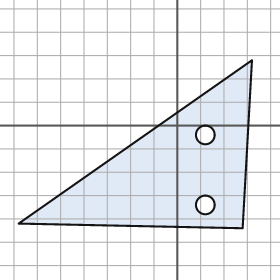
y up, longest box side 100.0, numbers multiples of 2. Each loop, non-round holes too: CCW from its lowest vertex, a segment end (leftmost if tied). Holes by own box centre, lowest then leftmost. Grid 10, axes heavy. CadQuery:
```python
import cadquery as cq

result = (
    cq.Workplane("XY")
    .moveTo(28.0, -44.0)
    .lineTo(32.0, 28.0)
    .lineTo(-68.0, -42.0)
    .close()
    .moveTo(12.0, -34.0)
    .circle(4.0)
    .moveTo(12.0, -4.0)
    .circle(4.0)
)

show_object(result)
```